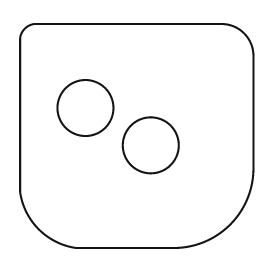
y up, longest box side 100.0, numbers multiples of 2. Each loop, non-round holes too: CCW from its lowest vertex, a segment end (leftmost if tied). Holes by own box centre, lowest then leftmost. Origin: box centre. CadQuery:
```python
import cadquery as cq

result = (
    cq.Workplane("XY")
    .moveTo(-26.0, -48.0)
    .lineTo(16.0, -48.0)
    .threePointArc((40.0, -38.0), (50.0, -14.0))
    .lineTo(50.0, 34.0)
    .threePointArc((46.0, 44.0), (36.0, 48.0))
    .lineTo(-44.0, 48.0)
    .threePointArc((-48.0, 46.0), (-50.0, 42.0))
    .lineTo(-50.0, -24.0)
    .threePointArc((-42.0, -40.0), (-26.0, -48.0))
    .close()
    .moveTo(6.0, -4.0)
    .circle(12.0)
    .moveTo(-22.0, 12.0)
    .circle(12.0)
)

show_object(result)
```